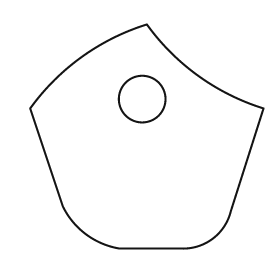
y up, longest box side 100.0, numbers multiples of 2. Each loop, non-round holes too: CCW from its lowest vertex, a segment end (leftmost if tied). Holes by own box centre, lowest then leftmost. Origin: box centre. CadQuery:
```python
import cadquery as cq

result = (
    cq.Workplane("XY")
    .moveTo(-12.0, -48.0)
    .lineTo(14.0, -48.0)
    .threePointArc((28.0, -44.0), (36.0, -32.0))
    .lineTo(50.0, 12.0)
    .threePointArc((22.0, 26.0), (0.0, 48.0))
    .threePointArc((-28.0, 34.0), (-50.0, 12.0))
    .lineTo(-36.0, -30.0)
    .threePointArc((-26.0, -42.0), (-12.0, -48.0))
    .close()
    .moveTo(-2.0, 16.0)
    .circle(10.0)
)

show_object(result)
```